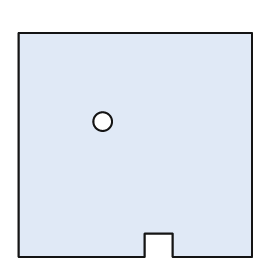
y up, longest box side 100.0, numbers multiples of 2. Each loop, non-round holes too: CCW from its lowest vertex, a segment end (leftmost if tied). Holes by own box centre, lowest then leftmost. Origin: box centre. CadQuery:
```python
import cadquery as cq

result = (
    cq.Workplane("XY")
    .moveTo(-50.0, -48.0)
    .lineTo(4.0, -48.0)
    .lineTo(4.0, -38.0)
    .lineTo(16.0, -38.0)
    .lineTo(16.0, -48.0)
    .lineTo(50.0, -48.0)
    .lineTo(50.0, 48.0)
    .lineTo(-50.0, 48.0)
    .close()
    .moveTo(-14.0, 10.0)
    .circle(4.0)
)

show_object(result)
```